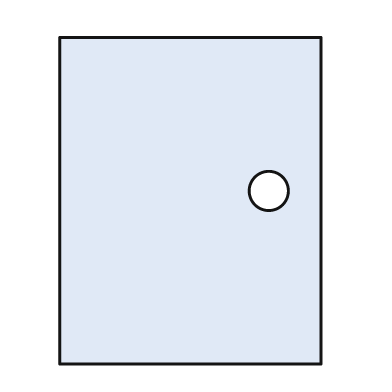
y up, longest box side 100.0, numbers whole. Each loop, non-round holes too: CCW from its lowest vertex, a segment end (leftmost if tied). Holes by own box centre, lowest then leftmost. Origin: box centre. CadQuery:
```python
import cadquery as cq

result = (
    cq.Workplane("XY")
    .moveTo(-40.0, -50.0)
    .lineTo(40.0, -50.0)
    .lineTo(40.0, 50.0)
    .lineTo(-40.0, 50.0)
    .close()
    .moveTo(24.0, 3.0)
    .circle(6.0)
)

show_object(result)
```